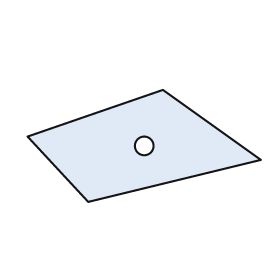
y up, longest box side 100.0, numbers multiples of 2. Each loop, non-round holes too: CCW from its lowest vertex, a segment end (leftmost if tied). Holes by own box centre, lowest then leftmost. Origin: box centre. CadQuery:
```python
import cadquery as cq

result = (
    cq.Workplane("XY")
    .moveTo(-24.0, -24.0)
    .lineTo(50.0, -6.0)
    .lineTo(8.0, 24.0)
    .lineTo(-50.0, 4.0)
    .close()
    .moveTo(0.0, 0.0)
    .circle(4.0)
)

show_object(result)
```